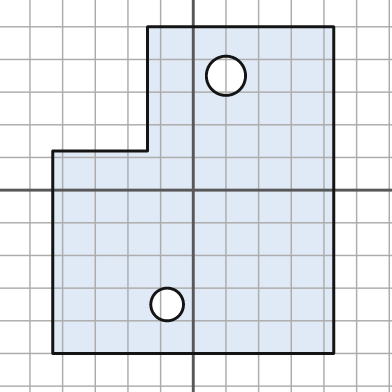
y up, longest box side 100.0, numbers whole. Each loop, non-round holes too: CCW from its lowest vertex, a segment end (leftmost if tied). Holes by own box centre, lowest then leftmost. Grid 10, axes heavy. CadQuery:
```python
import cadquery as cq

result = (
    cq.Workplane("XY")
    .moveTo(-43.0, -50.0)
    .lineTo(43.0, -50.0)
    .lineTo(43.0, 50.0)
    .lineTo(-14.0, 50.0)
    .lineTo(-14.0, 12.0)
    .lineTo(-43.0, 12.0)
    .close()
    .moveTo(-8.0, -35.0)
    .circle(5.0)
    .moveTo(10.0, 35.0)
    .circle(6.0)
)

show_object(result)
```